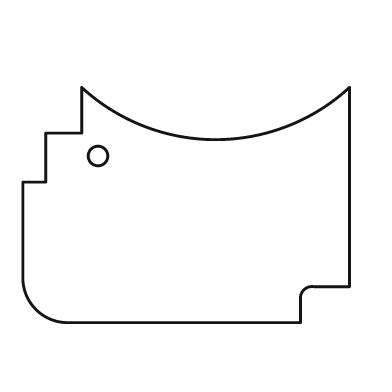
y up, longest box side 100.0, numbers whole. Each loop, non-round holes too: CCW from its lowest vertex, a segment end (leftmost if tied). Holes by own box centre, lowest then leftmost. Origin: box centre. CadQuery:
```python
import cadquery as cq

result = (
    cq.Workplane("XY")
    .moveTo(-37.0, -36.0)
    .lineTo(35.0, -36.0)
    .lineTo(35.0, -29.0)
    .threePointArc((36.0, -26.0), (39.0, -25.0))
    .lineTo(50.0, -25.0)
    .lineTo(50.0, 36.0)
    .threePointArc((9.0, 20.0), (-32.0, 36.0))
    .lineTo(-32.0, 22.0)
    .lineTo(-43.0, 22.0)
    .lineTo(-43.0, 7.0)
    .lineTo(-50.0, 7.0)
    .lineTo(-50.0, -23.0)
    .threePointArc((-46.0, -32.0), (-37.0, -36.0))
    .close()
    .moveTo(-27.0, 15.0)
    .circle(3.0)
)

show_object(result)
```